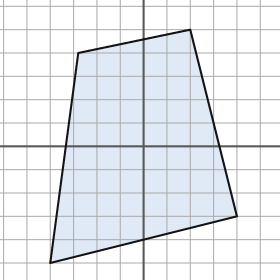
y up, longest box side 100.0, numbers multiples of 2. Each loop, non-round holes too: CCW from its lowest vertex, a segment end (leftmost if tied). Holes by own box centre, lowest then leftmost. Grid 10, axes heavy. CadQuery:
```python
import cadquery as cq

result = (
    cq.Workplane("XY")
    .moveTo(-40.0, -50.0)
    .lineTo(40.0, -30.0)
    .lineTo(20.0, 50.0)
    .lineTo(-28.0, 40.0)
    .close()
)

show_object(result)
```